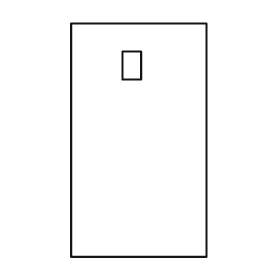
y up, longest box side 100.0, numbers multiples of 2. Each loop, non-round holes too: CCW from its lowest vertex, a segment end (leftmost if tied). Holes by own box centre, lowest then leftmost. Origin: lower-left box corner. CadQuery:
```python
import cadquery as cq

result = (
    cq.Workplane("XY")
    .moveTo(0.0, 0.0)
    .lineTo(58.0, 0.0)
    .lineTo(58.0, 100.0)
    .lineTo(0.0, 100.0)
    .close()
    .moveTo(22.0, 76.0)
    .lineTo(30.0, 76.0)
    .lineTo(30.0, 88.0)
    .lineTo(22.0, 88.0)
    .close()
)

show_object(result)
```